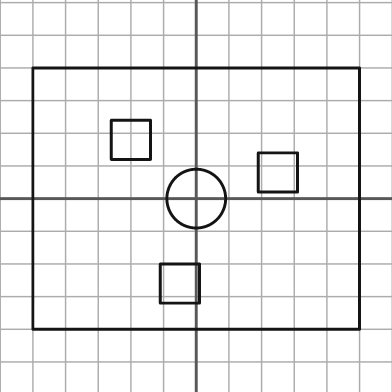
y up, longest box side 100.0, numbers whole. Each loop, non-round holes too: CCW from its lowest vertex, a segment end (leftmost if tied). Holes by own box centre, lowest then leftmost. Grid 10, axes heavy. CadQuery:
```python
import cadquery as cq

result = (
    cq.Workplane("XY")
    .moveTo(-50.0, -40.0)
    .lineTo(50.0, -40.0)
    .lineTo(50.0, 40.0)
    .lineTo(-50.0, 40.0)
    .close()
    .moveTo(-11.0, -32.0)
    .lineTo(1.0, -32.0)
    .lineTo(1.0, -20.0)
    .lineTo(-11.0, -20.0)
    .close()
    .moveTo(0.0, 0.0)
    .circle(9.0)
    .moveTo(19.0, 2.0)
    .lineTo(31.0, 2.0)
    .lineTo(31.0, 14.0)
    .lineTo(19.0, 14.0)
    .close()
    .moveTo(-26.0, 12.0)
    .lineTo(-14.0, 12.0)
    .lineTo(-14.0, 24.0)
    .lineTo(-26.0, 24.0)
    .close()
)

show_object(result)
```